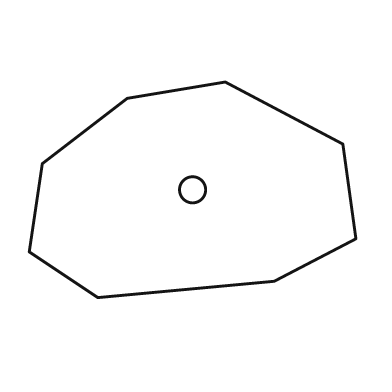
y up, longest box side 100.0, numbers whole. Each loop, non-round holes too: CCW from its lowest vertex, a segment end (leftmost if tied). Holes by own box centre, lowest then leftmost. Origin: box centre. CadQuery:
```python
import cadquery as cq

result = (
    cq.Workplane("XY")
    .moveTo(-29.0, -33.0)
    .lineTo(25.0, -28.0)
    .lineTo(50.0, -15.0)
    .lineTo(46.0, 14.0)
    .lineTo(10.0, 33.0)
    .lineTo(-20.0, 28.0)
    .lineTo(-46.0, 8.0)
    .lineTo(-50.0, -19.0)
    .close()
    .moveTo(0.0, 0.0)
    .circle(4.0)
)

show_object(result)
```